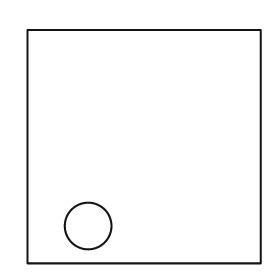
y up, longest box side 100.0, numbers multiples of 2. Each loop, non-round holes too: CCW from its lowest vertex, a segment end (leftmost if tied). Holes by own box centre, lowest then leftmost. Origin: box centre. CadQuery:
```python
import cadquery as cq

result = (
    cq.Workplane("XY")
    .moveTo(-50.0, -50.0)
    .lineTo(50.0, -50.0)
    .lineTo(50.0, 50.0)
    .lineTo(-50.0, 50.0)
    .close()
    .moveTo(-24.0, -34.0)
    .circle(10.0)
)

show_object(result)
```